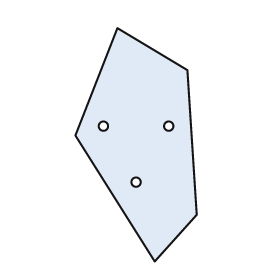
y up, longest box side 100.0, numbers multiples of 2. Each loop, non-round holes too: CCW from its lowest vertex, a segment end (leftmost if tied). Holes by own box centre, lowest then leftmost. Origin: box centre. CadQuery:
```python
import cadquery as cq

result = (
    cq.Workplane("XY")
    .moveTo(8.0, -50.0)
    .lineTo(26.0, -30.0)
    .lineTo(22.0, 32.0)
    .lineTo(-8.0, 50.0)
    .lineTo(-26.0, 4.0)
    .close()
    .moveTo(0.0, -16.0)
    .circle(2.0)
    .moveTo(-14.0, 8.0)
    .circle(2.0)
    .moveTo(14.0, 8.0)
    .circle(2.0)
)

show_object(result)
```